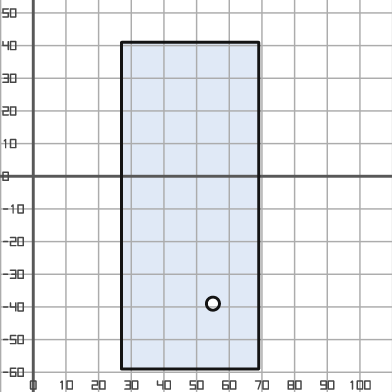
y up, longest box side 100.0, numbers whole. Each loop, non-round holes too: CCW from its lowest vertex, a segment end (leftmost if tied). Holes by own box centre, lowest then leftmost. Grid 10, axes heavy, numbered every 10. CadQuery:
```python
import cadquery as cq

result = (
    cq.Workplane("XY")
    .moveTo(27.0, -59.0)
    .lineTo(69.0, -59.0)
    .lineTo(69.0, 41.0)
    .lineTo(27.0, 41.0)
    .close()
    .moveTo(55.0, -39.0)
    .circle(2.0)
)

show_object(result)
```